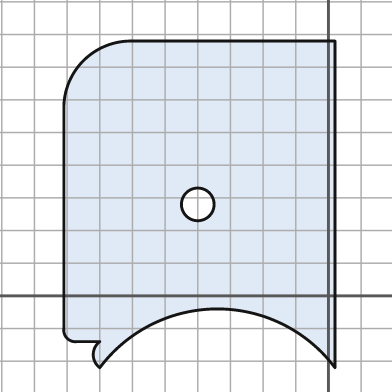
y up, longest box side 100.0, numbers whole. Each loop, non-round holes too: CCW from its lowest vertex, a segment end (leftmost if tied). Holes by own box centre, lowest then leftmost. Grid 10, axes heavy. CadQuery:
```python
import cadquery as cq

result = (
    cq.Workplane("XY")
    .moveTo(-70.0, -22.0)
    .threePointArc((-34.0, -4.0), (2.0, -22.0))
    .lineTo(2.0, 78.0)
    .lineTo(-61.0, 78.0)
    .threePointArc((-75.0, 72.0), (-81.0, 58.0))
    .lineTo(-81.0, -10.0)
    .threePointArc((-80.0, -13.0), (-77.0, -14.0))
    .lineTo(-70.0, -14.0)
    .threePointArc((-72.0, -18.0), (-70.0, -22.0))
    .close()
    .moveTo(-40.0, 28.0)
    .circle(5.0)
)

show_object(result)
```